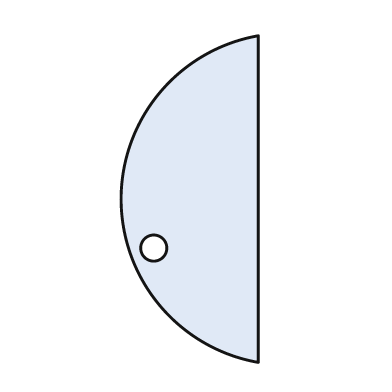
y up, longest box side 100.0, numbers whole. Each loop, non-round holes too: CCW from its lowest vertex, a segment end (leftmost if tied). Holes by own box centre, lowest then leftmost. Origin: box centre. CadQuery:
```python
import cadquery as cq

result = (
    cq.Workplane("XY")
    .moveTo(21.0, -50.0)
    .lineTo(21.0, 50.0)
    .threePointArc((-21.0, 0.0), (21.0, -50.0))
    .close()
    .moveTo(-11.0, -15.0)
    .circle(4.0)
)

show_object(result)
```